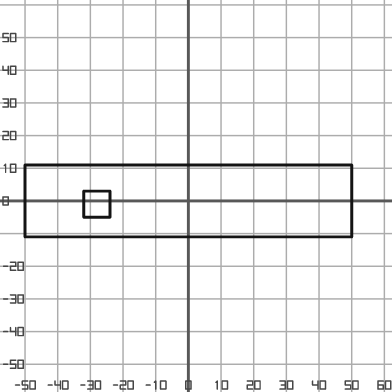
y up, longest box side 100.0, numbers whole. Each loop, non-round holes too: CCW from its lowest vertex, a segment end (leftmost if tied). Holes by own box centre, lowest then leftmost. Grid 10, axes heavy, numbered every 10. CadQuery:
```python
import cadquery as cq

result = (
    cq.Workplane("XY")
    .moveTo(-50.0, -11.0)
    .lineTo(50.0, -11.0)
    .lineTo(50.0, 11.0)
    .lineTo(-50.0, 11.0)
    .close()
    .moveTo(-32.0, -5.0)
    .lineTo(-24.0, -5.0)
    .lineTo(-24.0, 3.0)
    .lineTo(-32.0, 3.0)
    .close()
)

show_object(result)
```